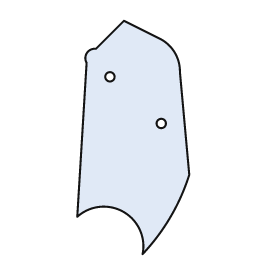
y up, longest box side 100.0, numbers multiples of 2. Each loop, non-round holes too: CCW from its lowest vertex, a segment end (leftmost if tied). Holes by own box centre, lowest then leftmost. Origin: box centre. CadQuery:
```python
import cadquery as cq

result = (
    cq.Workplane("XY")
    .moveTo(4.0, -50.0)
    .threePointArc((16.0, -34.0), (24.0, -16.0))
    .lineTo(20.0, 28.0)
    .threePointArc((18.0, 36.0), (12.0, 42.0))
    .lineTo(-4.0, 50.0)
    .lineTo(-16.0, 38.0)
    .threePointArc((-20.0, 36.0), (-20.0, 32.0))
    .lineTo(-24.0, -34.0)
    .threePointArc((-4.0, -32.0), (4.0, -50.0))
    .close()
    .moveTo(12.0, 6.0)
    .circle(2.0)
    .moveTo(-10.0, 26.0)
    .circle(2.0)
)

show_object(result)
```